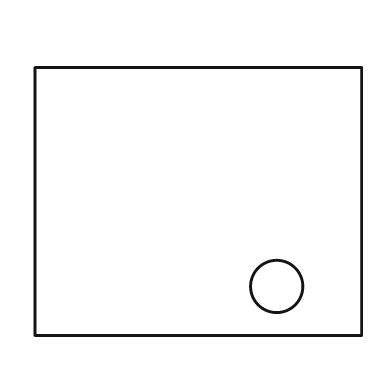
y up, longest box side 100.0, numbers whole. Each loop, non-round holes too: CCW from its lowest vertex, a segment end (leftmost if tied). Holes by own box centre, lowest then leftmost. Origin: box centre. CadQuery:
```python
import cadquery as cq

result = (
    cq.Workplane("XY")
    .moveTo(-50.0, -41.0)
    .lineTo(50.0, -41.0)
    .lineTo(50.0, 41.0)
    .lineTo(-50.0, 41.0)
    .close()
    .moveTo(24.0, -26.0)
    .circle(8.0)
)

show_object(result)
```